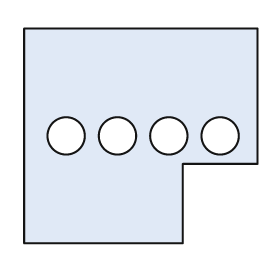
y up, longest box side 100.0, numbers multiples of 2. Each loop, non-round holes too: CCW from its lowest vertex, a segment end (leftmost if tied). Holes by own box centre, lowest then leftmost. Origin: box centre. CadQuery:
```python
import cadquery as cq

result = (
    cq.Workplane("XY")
    .moveTo(-50.0, -46.0)
    .lineTo(18.0, -46.0)
    .lineTo(18.0, -12.0)
    .lineTo(50.0, -12.0)
    .lineTo(50.0, 46.0)
    .lineTo(-50.0, 46.0)
    .close()
    .moveTo(-32.0, 0.0)
    .circle(8.0)
    .moveTo(-10.0, 0.0)
    .circle(8.0)
    .moveTo(12.0, 0.0)
    .circle(8.0)
    .moveTo(34.0, 0.0)
    .circle(8.0)
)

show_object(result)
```